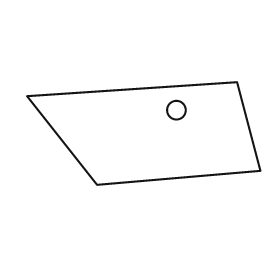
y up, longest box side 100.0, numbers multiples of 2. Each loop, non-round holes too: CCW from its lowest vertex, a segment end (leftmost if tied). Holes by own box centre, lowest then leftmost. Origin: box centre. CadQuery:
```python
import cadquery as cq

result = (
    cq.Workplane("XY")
    .moveTo(-20.0, -22.0)
    .lineTo(50.0, -16.0)
    .lineTo(40.0, 22.0)
    .lineTo(-50.0, 16.0)
    .close()
    .moveTo(14.0, 10.0)
    .circle(4.0)
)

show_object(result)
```